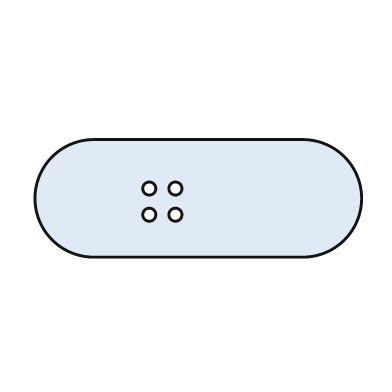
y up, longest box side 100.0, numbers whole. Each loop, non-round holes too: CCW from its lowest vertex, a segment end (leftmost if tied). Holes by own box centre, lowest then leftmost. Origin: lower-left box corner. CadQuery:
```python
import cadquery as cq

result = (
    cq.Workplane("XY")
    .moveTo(18.0, 0.0)
    .lineTo(82.0, 0.0)
    .threePointArc((100.0, 18.0), (82.0, 36.0))
    .lineTo(18.0, 36.0)
    .threePointArc((0.0, 18.0), (18.0, 0.0))
    .close()
    .moveTo(35.0, 13.0)
    .circle(2.0)
    .moveTo(43.0, 13.0)
    .circle(2.0)
    .moveTo(35.0, 21.0)
    .circle(2.0)
    .moveTo(43.0, 21.0)
    .circle(2.0)
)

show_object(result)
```